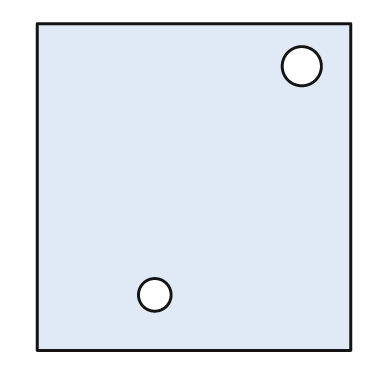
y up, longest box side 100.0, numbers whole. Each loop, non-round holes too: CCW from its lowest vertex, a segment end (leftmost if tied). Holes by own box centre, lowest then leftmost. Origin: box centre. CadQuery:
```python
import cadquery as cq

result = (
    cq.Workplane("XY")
    .moveTo(-48.0, -50.0)
    .lineTo(48.0, -50.0)
    .lineTo(48.0, 50.0)
    .lineTo(-48.0, 50.0)
    .close()
    .moveTo(-12.0, -33.0)
    .circle(5.0)
    .moveTo(33.0, 37.0)
    .circle(6.0)
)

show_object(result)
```